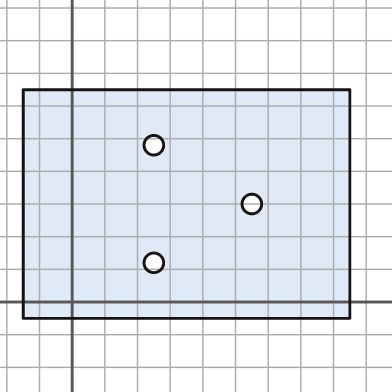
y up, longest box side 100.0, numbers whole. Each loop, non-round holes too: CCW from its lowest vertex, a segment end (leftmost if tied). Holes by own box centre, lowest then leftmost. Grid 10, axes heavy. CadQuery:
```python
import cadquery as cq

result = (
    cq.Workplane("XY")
    .moveTo(-15.0, -5.0)
    .lineTo(85.0, -5.0)
    .lineTo(85.0, 65.0)
    .lineTo(-15.0, 65.0)
    .close()
    .moveTo(25.0, 12.0)
    .circle(3.0)
    .moveTo(55.0, 30.0)
    .circle(3.0)
    .moveTo(25.0, 48.0)
    .circle(3.0)
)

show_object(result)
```